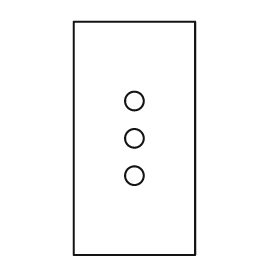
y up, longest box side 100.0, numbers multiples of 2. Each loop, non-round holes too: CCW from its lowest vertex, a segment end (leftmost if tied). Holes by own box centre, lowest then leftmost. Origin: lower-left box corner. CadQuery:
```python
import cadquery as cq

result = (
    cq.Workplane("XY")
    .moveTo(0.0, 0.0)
    .lineTo(52.0, 0.0)
    .lineTo(52.0, 100.0)
    .lineTo(0.0, 100.0)
    .close()
    .moveTo(26.0, 34.0)
    .circle(4.0)
    .moveTo(26.0, 50.0)
    .circle(4.0)
    .moveTo(26.0, 66.0)
    .circle(4.0)
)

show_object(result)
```